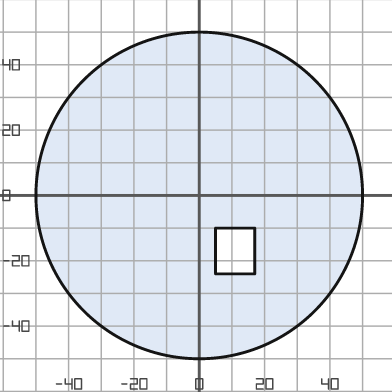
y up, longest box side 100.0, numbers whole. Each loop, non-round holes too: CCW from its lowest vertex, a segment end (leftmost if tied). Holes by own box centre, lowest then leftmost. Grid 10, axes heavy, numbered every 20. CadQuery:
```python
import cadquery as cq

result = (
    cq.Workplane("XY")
    .moveTo(0.0, 0.0)
    .circle(50.0)
    .moveTo(5.0, -24.0)
    .lineTo(17.0, -24.0)
    .lineTo(17.0, -10.0)
    .lineTo(5.0, -10.0)
    .close()
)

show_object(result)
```